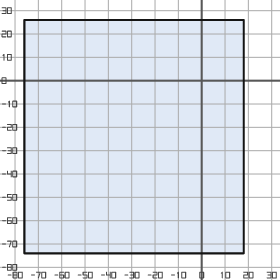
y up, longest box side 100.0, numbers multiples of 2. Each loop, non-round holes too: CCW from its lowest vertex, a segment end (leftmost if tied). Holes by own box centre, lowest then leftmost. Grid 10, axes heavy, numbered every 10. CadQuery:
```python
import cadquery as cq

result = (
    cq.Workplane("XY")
    .moveTo(-76.0, -74.0)
    .lineTo(18.0, -74.0)
    .lineTo(18.0, 26.0)
    .lineTo(-76.0, 26.0)
    .close()
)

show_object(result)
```